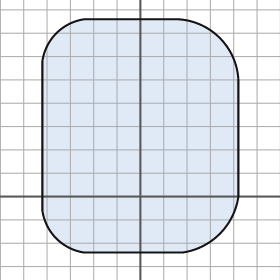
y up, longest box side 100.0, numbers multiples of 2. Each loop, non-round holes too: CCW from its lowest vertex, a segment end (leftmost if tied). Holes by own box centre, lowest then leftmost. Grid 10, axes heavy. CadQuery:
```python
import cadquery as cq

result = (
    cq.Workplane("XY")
    .moveTo(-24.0, -24.0)
    .lineTo(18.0, -24.0)
    .threePointArc((34.0, -16.0), (42.0, 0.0))
    .lineTo(42.0, 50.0)
    .threePointArc((34.0, 68.0), (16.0, 76.0))
    .lineTo(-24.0, 76.0)
    .threePointArc((-36.0, 70.0), (-42.0, 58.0))
    .lineTo(-42.0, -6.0)
    .threePointArc((-36.0, -18.0), (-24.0, -24.0))
    .close()
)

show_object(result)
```